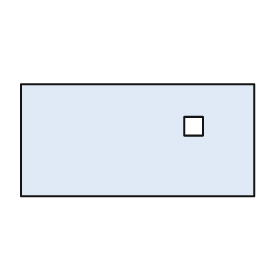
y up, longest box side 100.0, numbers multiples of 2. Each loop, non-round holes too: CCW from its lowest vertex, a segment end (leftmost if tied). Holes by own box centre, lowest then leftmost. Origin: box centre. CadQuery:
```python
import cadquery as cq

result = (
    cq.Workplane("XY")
    .moveTo(-50.0, -24.0)
    .lineTo(50.0, -24.0)
    .lineTo(50.0, 24.0)
    .lineTo(-50.0, 24.0)
    .close()
    .moveTo(20.0, 2.0)
    .lineTo(28.0, 2.0)
    .lineTo(28.0, 10.0)
    .lineTo(20.0, 10.0)
    .close()
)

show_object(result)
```